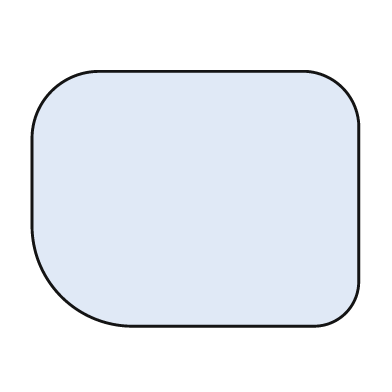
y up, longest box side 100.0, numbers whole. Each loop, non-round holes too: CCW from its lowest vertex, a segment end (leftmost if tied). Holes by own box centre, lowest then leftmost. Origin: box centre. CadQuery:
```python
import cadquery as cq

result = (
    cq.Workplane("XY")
    .moveTo(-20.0, -39.0)
    .lineTo(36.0, -39.0)
    .threePointArc((46.0, -35.0), (50.0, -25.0))
    .lineTo(50.0, 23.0)
    .threePointArc((45.0, 34.0), (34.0, 39.0))
    .lineTo(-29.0, 39.0)
    .threePointArc((-44.0, 33.0), (-50.0, 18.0))
    .lineTo(-50.0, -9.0)
    .threePointArc((-41.0, -30.0), (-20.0, -39.0))
    .close()
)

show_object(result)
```